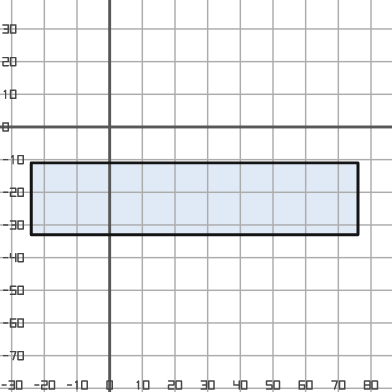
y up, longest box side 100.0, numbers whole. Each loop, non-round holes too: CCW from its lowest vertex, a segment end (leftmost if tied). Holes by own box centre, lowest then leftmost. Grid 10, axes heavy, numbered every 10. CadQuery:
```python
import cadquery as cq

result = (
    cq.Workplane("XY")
    .moveTo(-24.0, -33.0)
    .lineTo(76.0, -33.0)
    .lineTo(76.0, -11.0)
    .lineTo(-24.0, -11.0)
    .close()
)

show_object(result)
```